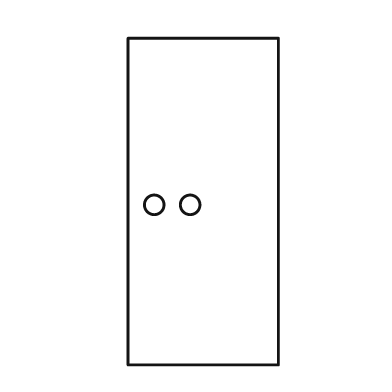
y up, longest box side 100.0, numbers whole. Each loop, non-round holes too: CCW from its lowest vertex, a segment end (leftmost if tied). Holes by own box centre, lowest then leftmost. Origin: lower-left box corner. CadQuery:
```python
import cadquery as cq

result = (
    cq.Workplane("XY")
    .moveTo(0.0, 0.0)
    .lineTo(46.0, 0.0)
    .lineTo(46.0, 100.0)
    .lineTo(0.0, 100.0)
    .close()
    .moveTo(8.0, 49.0)
    .circle(3.0)
    .moveTo(19.0, 49.0)
    .circle(3.0)
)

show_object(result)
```